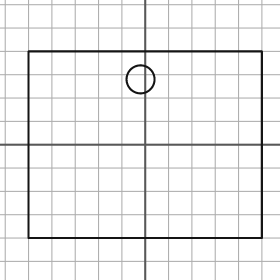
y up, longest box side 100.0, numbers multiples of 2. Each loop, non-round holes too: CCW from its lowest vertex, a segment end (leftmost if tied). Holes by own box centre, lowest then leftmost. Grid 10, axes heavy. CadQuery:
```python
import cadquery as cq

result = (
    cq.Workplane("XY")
    .moveTo(-50.0, -40.0)
    .lineTo(50.0, -40.0)
    .lineTo(50.0, 40.0)
    .lineTo(-50.0, 40.0)
    .close()
    .moveTo(-2.0, 28.0)
    .circle(6.0)
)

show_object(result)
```